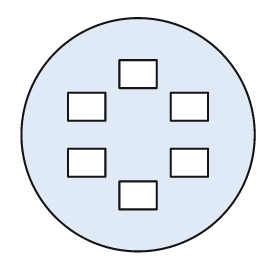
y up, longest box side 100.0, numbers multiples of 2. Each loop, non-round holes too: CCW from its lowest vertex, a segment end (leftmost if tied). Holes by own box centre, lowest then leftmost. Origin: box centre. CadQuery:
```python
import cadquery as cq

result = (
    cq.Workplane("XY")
    .moveTo(0.0, 0.0)
    .circle(50.0)
    .moveTo(-8.0, -32.0)
    .lineTo(8.0, -32.0)
    .lineTo(8.0, -20.0)
    .lineTo(-8.0, -20.0)
    .close()
    .moveTo(-30.0, -18.0)
    .lineTo(-14.0, -18.0)
    .lineTo(-14.0, -6.0)
    .lineTo(-30.0, -6.0)
    .close()
    .moveTo(14.0, -18.0)
    .lineTo(30.0, -18.0)
    .lineTo(30.0, -6.0)
    .lineTo(14.0, -6.0)
    .close()
    .moveTo(-30.0, 6.0)
    .lineTo(-14.0, 6.0)
    .lineTo(-14.0, 18.0)
    .lineTo(-30.0, 18.0)
    .close()
    .moveTo(14.0, 6.0)
    .lineTo(30.0, 6.0)
    .lineTo(30.0, 18.0)
    .lineTo(14.0, 18.0)
    .close()
    .moveTo(-8.0, 20.0)
    .lineTo(8.0, 20.0)
    .lineTo(8.0, 32.0)
    .lineTo(-8.0, 32.0)
    .close()
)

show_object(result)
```